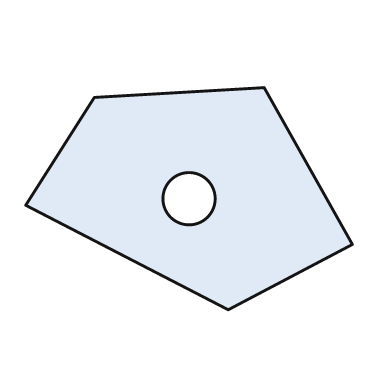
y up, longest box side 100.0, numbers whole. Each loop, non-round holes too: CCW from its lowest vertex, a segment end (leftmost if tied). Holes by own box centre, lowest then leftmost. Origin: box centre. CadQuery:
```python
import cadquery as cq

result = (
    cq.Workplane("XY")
    .moveTo(12.0, -34.0)
    .lineTo(50.0, -14.0)
    .lineTo(23.0, 34.0)
    .lineTo(-29.0, 31.0)
    .lineTo(-50.0, -2.0)
    .close()
    .moveTo(0.0, 0.0)
    .circle(8.0)
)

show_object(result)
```